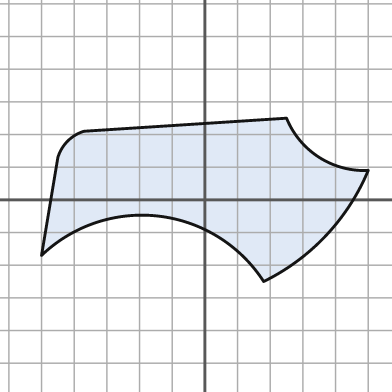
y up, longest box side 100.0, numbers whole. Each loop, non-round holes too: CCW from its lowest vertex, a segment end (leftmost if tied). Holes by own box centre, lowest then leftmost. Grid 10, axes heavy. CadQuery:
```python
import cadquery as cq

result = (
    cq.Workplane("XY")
    .moveTo(18.0, -25.0)
    .threePointArc((37.0, -11.0), (50.0, 9.0))
    .threePointArc((35.0, 13.0), (25.0, 25.0))
    .lineTo(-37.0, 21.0)
    .threePointArc((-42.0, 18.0), (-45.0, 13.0))
    .lineTo(-50.0, -17.0)
    .threePointArc((-14.0, -5.0), (18.0, -25.0))
    .close()
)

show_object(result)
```